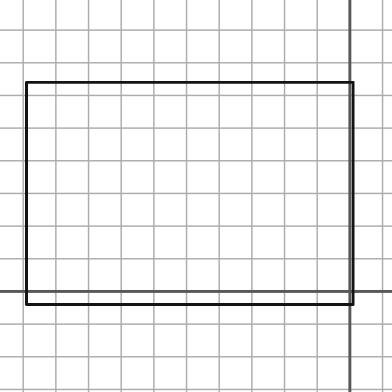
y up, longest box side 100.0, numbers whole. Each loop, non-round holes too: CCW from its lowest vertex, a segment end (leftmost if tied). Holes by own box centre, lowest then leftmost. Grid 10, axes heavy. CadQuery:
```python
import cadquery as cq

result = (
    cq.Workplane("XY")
    .moveTo(-99.0, -4.0)
    .lineTo(1.0, -4.0)
    .lineTo(1.0, 64.0)
    .lineTo(-99.0, 64.0)
    .close()
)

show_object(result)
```